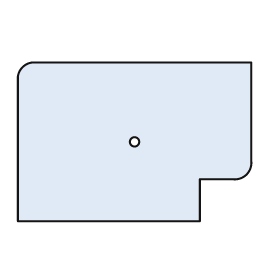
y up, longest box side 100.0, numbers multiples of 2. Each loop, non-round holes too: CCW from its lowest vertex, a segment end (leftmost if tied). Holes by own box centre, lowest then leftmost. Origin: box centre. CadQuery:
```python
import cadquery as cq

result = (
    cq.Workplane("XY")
    .moveTo(-50.0, -34.0)
    .lineTo(28.0, -34.0)
    .lineTo(28.0, -16.0)
    .lineTo(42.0, -16.0)
    .threePointArc((48.0, -14.0), (50.0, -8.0))
    .lineTo(50.0, 34.0)
    .lineTo(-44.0, 34.0)
    .threePointArc((-48.0, 32.0), (-50.0, 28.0))
    .close()
    .moveTo(0.0, 0.0)
    .circle(2.0)
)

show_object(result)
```